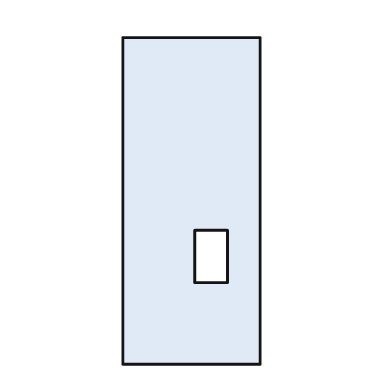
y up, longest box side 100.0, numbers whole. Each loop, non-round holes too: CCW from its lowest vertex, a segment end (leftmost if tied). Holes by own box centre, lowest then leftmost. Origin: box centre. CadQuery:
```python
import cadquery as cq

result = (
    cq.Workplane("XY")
    .moveTo(-21.0, -50.0)
    .lineTo(21.0, -50.0)
    .lineTo(21.0, 50.0)
    .lineTo(-21.0, 50.0)
    .close()
    .moveTo(1.0, -25.0)
    .lineTo(11.0, -25.0)
    .lineTo(11.0, -9.0)
    .lineTo(1.0, -9.0)
    .close()
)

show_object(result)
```